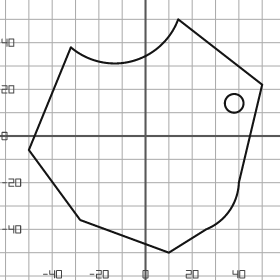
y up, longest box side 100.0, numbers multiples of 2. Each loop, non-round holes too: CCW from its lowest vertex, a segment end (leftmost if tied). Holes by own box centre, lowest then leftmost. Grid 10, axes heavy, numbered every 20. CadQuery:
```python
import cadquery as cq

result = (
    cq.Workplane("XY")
    .moveTo(10.0, -50.0)
    .lineTo(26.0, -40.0)
    .threePointArc((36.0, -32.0), (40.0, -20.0))
    .lineTo(50.0, 22.0)
    .lineTo(14.0, 50.0)
    .threePointArc((-6.0, 32.0), (-32.0, 38.0))
    .lineTo(-50.0, -6.0)
    .lineTo(-28.0, -36.0)
    .close()
    .moveTo(38.0, 14.0)
    .circle(4.0)
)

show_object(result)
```